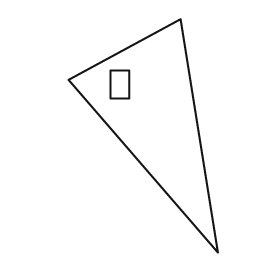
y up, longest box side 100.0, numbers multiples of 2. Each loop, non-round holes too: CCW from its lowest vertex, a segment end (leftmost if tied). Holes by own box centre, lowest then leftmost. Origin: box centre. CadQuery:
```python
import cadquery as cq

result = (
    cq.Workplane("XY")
    .moveTo(32.0, -50.0)
    .lineTo(16.0, 50.0)
    .lineTo(-32.0, 24.0)
    .close()
    .moveTo(-14.0, 16.0)
    .lineTo(-6.0, 16.0)
    .lineTo(-6.0, 28.0)
    .lineTo(-14.0, 28.0)
    .close()
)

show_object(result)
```